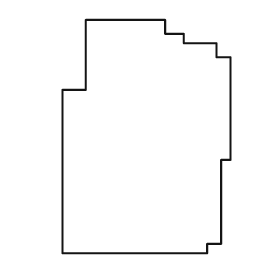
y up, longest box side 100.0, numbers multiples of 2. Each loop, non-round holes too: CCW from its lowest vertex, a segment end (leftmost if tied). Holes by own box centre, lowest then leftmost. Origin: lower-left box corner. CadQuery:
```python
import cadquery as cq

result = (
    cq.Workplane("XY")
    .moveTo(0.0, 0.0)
    .lineTo(62.0, 0.0)
    .lineTo(62.0, 4.0)
    .lineTo(68.0, 4.0)
    .lineTo(68.0, 40.0)
    .lineTo(72.0, 40.0)
    .lineTo(72.0, 84.0)
    .lineTo(66.0, 84.0)
    .lineTo(66.0, 90.0)
    .lineTo(52.0, 90.0)
    .lineTo(52.0, 94.0)
    .lineTo(44.0, 94.0)
    .lineTo(44.0, 100.0)
    .lineTo(10.0, 100.0)
    .lineTo(10.0, 70.0)
    .lineTo(0.0, 70.0)
    .close()
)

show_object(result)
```